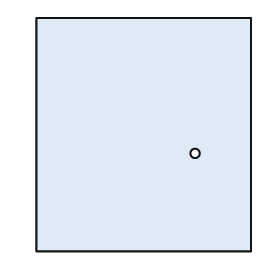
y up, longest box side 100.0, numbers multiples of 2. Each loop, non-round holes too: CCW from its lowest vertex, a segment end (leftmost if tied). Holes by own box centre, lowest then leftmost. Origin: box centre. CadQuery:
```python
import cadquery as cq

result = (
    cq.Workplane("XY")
    .moveTo(-46.0, -50.0)
    .lineTo(46.0, -50.0)
    .lineTo(46.0, 50.0)
    .lineTo(-46.0, 50.0)
    .close()
    .moveTo(22.0, -8.0)
    .circle(2.0)
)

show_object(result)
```